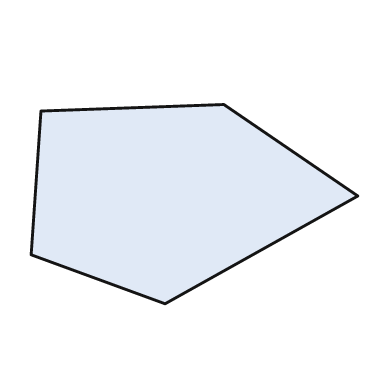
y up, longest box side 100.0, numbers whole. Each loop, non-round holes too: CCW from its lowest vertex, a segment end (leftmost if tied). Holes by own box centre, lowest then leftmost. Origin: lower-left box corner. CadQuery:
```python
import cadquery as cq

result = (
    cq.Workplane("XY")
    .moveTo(41.0, 0.0)
    .lineTo(100.0, 33.0)
    .lineTo(59.0, 61.0)
    .lineTo(3.0, 59.0)
    .lineTo(0.0, 15.0)
    .close()
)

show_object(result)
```